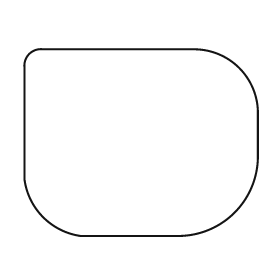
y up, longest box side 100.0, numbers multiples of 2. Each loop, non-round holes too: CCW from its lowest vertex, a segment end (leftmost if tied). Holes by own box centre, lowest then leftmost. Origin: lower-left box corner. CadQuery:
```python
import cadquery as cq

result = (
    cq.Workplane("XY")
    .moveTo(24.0, 0.0)
    .lineTo(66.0, 0.0)
    .threePointArc((90.0, 10.0), (100.0, 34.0))
    .lineTo(100.0, 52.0)
    .threePointArc((92.0, 72.0), (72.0, 80.0))
    .lineTo(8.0, 80.0)
    .threePointArc((2.0, 78.0), (0.0, 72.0))
    .lineTo(0.0, 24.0)
    .threePointArc((8.0, 8.0), (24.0, 0.0))
    .close()
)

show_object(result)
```